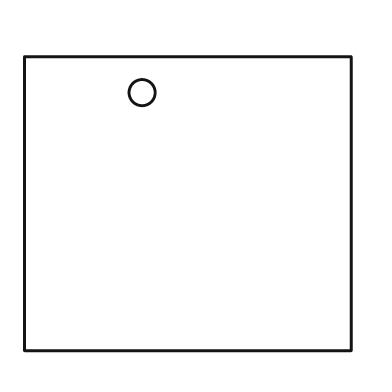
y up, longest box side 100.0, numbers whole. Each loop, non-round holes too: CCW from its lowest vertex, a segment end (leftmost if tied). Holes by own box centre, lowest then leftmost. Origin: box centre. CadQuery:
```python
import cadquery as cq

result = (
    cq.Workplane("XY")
    .moveTo(-50.0, -45.0)
    .lineTo(50.0, -45.0)
    .lineTo(50.0, 45.0)
    .lineTo(-50.0, 45.0)
    .close()
    .moveTo(-14.0, 34.0)
    .circle(4.0)
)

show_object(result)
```